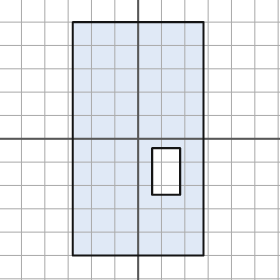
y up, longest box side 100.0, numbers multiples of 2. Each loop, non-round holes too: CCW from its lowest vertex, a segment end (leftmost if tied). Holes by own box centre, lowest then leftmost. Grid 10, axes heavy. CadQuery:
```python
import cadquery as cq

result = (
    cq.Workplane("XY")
    .moveTo(-28.0, -50.0)
    .lineTo(28.0, -50.0)
    .lineTo(28.0, 50.0)
    .lineTo(-28.0, 50.0)
    .close()
    .moveTo(6.0, -24.0)
    .lineTo(18.0, -24.0)
    .lineTo(18.0, -4.0)
    .lineTo(6.0, -4.0)
    .close()
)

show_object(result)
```